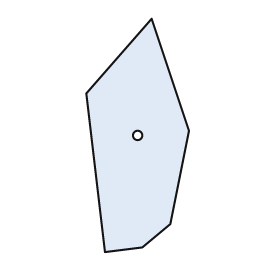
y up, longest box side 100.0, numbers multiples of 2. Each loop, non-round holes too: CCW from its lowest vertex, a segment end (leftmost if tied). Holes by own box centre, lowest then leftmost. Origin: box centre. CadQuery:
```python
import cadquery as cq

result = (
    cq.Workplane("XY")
    .moveTo(-14.0, -50.0)
    .lineTo(2.0, -48.0)
    .lineTo(14.0, -38.0)
    .lineTo(22.0, 2.0)
    .lineTo(6.0, 50.0)
    .lineTo(-22.0, 18.0)
    .close()
    .moveTo(0.0, 0.0)
    .circle(2.0)
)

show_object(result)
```